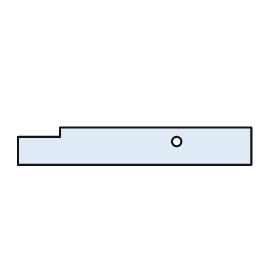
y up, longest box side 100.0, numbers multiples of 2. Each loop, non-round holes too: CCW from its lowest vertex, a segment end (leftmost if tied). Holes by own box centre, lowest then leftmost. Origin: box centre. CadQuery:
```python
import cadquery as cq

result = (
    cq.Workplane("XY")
    .moveTo(-50.0, -8.0)
    .lineTo(50.0, -8.0)
    .lineTo(50.0, 8.0)
    .lineTo(-32.0, 8.0)
    .lineTo(-32.0, 4.0)
    .lineTo(-50.0, 4.0)
    .close()
    .moveTo(18.0, 2.0)
    .circle(2.0)
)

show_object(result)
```